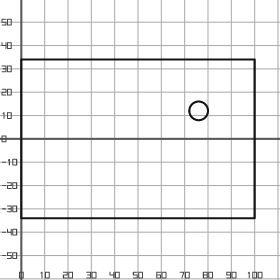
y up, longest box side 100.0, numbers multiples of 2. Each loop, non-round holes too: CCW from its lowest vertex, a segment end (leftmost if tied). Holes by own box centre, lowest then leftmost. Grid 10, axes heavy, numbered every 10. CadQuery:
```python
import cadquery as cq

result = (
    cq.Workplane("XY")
    .moveTo(0.0, -34.0)
    .lineTo(100.0, -34.0)
    .lineTo(100.0, 34.0)
    .lineTo(0.0, 34.0)
    .close()
    .moveTo(76.0, 12.0)
    .circle(4.0)
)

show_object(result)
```